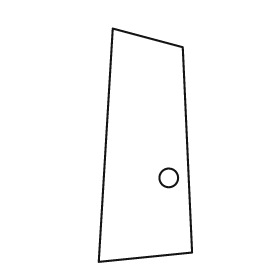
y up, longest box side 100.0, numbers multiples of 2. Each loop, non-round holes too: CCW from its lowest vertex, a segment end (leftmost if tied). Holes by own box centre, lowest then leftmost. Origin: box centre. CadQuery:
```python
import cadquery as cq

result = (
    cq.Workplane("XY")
    .moveTo(-20.0, -50.0)
    .lineTo(20.0, -46.0)
    .lineTo(16.0, 42.0)
    .lineTo(-14.0, 50.0)
    .close()
    .moveTo(10.0, -14.0)
    .circle(4.0)
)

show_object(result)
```